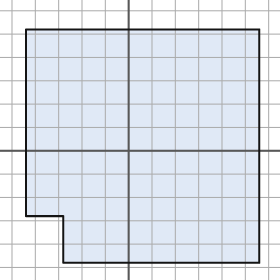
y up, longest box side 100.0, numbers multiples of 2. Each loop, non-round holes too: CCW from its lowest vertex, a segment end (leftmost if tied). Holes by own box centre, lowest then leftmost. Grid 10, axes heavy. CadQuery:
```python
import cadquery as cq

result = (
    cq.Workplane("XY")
    .moveTo(-28.0, -48.0)
    .lineTo(56.0, -48.0)
    .lineTo(56.0, 52.0)
    .lineTo(-44.0, 52.0)
    .lineTo(-44.0, -28.0)
    .lineTo(-28.0, -28.0)
    .close()
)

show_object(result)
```